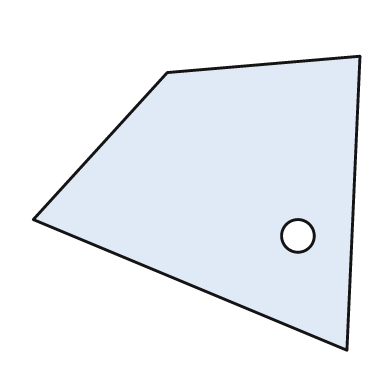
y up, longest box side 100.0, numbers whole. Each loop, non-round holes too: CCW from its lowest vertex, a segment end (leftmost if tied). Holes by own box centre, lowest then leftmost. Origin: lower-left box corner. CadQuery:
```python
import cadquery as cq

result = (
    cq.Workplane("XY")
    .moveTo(96.0, 0.0)
    .lineTo(100.0, 90.0)
    .lineTo(41.0, 85.0)
    .lineTo(0.0, 40.0)
    .close()
    .moveTo(81.0, 35.0)
    .circle(5.0)
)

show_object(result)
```